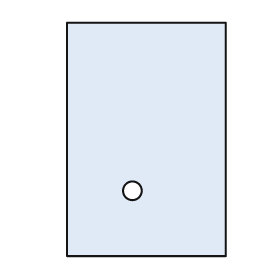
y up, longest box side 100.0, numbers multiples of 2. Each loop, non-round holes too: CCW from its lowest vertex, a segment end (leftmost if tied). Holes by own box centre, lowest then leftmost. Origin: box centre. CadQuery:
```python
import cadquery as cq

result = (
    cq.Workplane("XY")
    .moveTo(-34.0, -50.0)
    .lineTo(34.0, -50.0)
    .lineTo(34.0, 50.0)
    .lineTo(-34.0, 50.0)
    .close()
    .moveTo(-6.0, -22.0)
    .circle(4.0)
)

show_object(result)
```